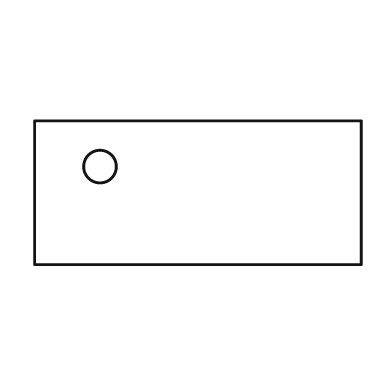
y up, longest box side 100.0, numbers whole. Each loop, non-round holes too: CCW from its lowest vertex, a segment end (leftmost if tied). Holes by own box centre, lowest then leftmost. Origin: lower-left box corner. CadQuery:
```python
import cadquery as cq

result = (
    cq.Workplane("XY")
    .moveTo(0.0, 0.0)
    .lineTo(100.0, 0.0)
    .lineTo(100.0, 44.0)
    .lineTo(0.0, 44.0)
    .close()
    .moveTo(20.0, 30.0)
    .circle(5.0)
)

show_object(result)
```